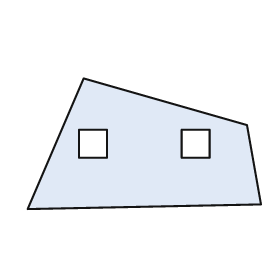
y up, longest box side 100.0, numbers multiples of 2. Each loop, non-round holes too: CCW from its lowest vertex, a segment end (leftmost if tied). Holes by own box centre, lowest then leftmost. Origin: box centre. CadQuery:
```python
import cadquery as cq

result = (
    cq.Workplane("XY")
    .moveTo(-50.0, -28.0)
    .lineTo(50.0, -26.0)
    .lineTo(44.0, 8.0)
    .lineTo(-26.0, 28.0)
    .close()
    .moveTo(-28.0, -6.0)
    .lineTo(-16.0, -6.0)
    .lineTo(-16.0, 6.0)
    .lineTo(-28.0, 6.0)
    .close()
    .moveTo(16.0, -6.0)
    .lineTo(28.0, -6.0)
    .lineTo(28.0, 6.0)
    .lineTo(16.0, 6.0)
    .close()
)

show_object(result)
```